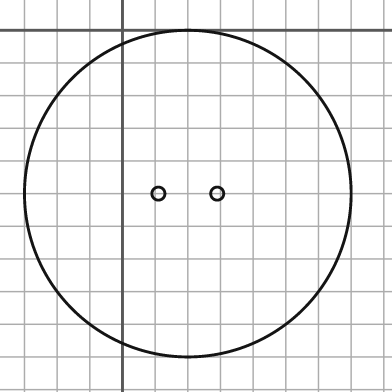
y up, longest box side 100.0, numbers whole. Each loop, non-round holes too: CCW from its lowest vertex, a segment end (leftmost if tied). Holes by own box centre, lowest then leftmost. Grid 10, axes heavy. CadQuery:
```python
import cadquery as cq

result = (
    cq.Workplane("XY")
    .moveTo(20.0, -50.0)
    .circle(50.0)
    .moveTo(11.0, -50.0)
    .circle(2.0)
    .moveTo(29.0, -50.0)
    .circle(2.0)
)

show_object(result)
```